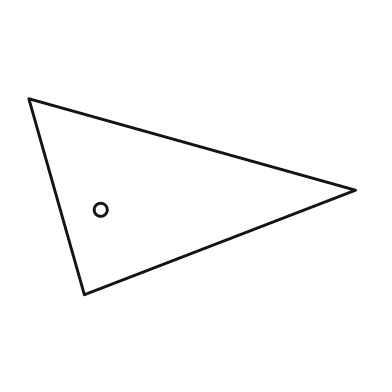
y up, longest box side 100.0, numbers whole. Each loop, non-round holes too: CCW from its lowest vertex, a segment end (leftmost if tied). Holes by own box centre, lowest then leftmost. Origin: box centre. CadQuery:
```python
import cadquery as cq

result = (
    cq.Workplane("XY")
    .moveTo(-33.0, -30.0)
    .lineTo(50.0, 2.0)
    .lineTo(-50.0, 30.0)
    .close()
    .moveTo(-28.0, -4.0)
    .circle(2.0)
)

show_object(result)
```